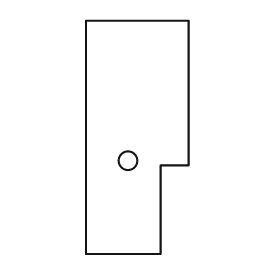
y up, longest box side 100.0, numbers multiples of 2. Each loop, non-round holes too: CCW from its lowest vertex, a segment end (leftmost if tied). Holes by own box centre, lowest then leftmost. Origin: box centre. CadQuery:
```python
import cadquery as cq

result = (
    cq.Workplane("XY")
    .moveTo(-22.0, -50.0)
    .lineTo(10.0, -50.0)
    .lineTo(10.0, -12.0)
    .lineTo(22.0, -12.0)
    .lineTo(22.0, 50.0)
    .lineTo(-22.0, 50.0)
    .close()
    .moveTo(-4.0, -10.0)
    .circle(4.0)
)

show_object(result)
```